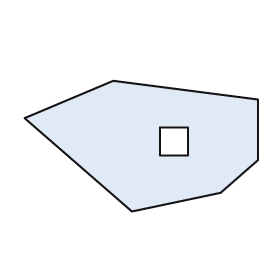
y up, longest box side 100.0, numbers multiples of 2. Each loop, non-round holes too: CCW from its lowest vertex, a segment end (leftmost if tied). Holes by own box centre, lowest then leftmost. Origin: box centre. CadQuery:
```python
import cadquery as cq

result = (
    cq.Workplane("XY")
    .moveTo(-4.0, -28.0)
    .lineTo(34.0, -20.0)
    .lineTo(50.0, -6.0)
    .lineTo(50.0, 20.0)
    .lineTo(-12.0, 28.0)
    .lineTo(-50.0, 12.0)
    .close()
    .moveTo(8.0, -4.0)
    .lineTo(20.0, -4.0)
    .lineTo(20.0, 8.0)
    .lineTo(8.0, 8.0)
    .close()
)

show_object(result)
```